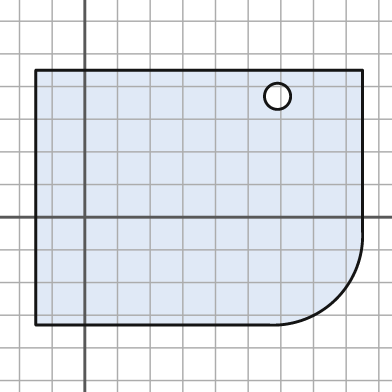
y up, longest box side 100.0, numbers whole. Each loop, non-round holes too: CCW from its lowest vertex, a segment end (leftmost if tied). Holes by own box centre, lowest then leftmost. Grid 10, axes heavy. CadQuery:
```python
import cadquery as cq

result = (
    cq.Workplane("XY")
    .moveTo(-15.0, -33.0)
    .lineTo(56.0, -33.0)
    .threePointArc((77.0, -25.0), (85.0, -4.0))
    .lineTo(85.0, 45.0)
    .lineTo(-15.0, 45.0)
    .close()
    .moveTo(59.0, 37.0)
    .circle(4.0)
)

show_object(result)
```